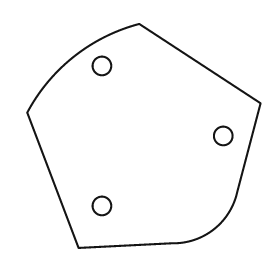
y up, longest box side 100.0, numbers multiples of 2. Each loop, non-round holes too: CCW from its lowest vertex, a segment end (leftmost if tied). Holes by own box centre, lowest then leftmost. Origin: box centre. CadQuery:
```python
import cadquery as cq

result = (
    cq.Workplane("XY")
    .moveTo(-28.0, -48.0)
    .lineTo(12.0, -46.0)
    .threePointArc((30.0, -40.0), (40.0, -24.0))
    .lineTo(50.0, 14.0)
    .lineTo(-2.0, 48.0)
    .threePointArc((-30.0, 34.0), (-50.0, 10.0))
    .close()
    .moveTo(-18.0, -30.0)
    .circle(4.0)
    .moveTo(34.0, 0.0)
    .circle(4.0)
    .moveTo(-18.0, 30.0)
    .circle(4.0)
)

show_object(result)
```